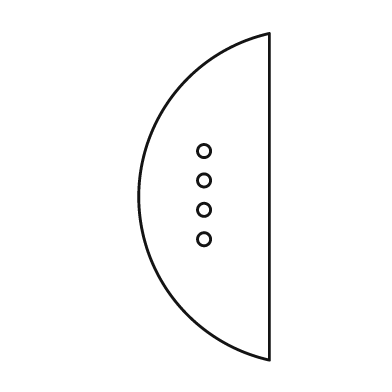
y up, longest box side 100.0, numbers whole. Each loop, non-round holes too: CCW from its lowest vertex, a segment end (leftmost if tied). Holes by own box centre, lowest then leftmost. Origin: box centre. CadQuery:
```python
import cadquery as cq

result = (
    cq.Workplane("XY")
    .moveTo(20.0, -50.0)
    .lineTo(20.0, 50.0)
    .threePointArc((-20.0, 0.0), (20.0, -50.0))
    .close()
    .moveTo(0.0, -13.0)
    .circle(2.0)
    .moveTo(0.0, -4.0)
    .circle(2.0)
    .moveTo(0.0, 5.0)
    .circle(2.0)
    .moveTo(0.0, 14.0)
    .circle(2.0)
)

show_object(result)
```